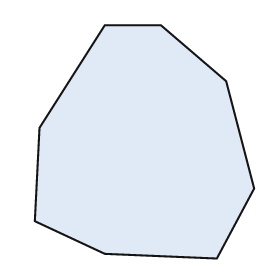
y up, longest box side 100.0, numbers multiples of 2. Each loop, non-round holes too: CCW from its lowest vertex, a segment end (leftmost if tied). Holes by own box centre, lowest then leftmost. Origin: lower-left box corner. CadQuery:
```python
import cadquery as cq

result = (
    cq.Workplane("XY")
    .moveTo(78.0, 0.0)
    .lineTo(94.0, 30.0)
    .lineTo(82.0, 76.0)
    .lineTo(54.0, 100.0)
    .lineTo(30.0, 100.0)
    .lineTo(2.0, 56.0)
    .lineTo(0.0, 16.0)
    .lineTo(30.0, 2.0)
    .close()
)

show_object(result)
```